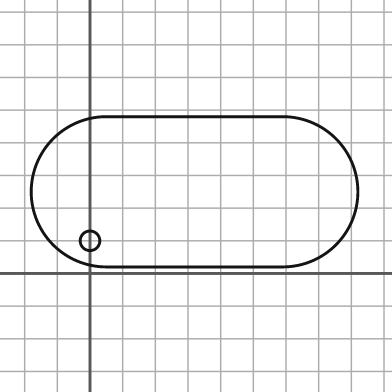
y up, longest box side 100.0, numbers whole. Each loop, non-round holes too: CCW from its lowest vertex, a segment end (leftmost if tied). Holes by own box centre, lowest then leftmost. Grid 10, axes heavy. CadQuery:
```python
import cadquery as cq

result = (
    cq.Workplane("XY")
    .moveTo(5.0, 2.0)
    .lineTo(59.0, 2.0)
    .threePointArc((82.0, 25.0), (59.0, 48.0))
    .lineTo(5.0, 48.0)
    .threePointArc((-18.0, 25.0), (5.0, 2.0))
    .close()
    .moveTo(0.0, 10.0)
    .circle(3.0)
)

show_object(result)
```